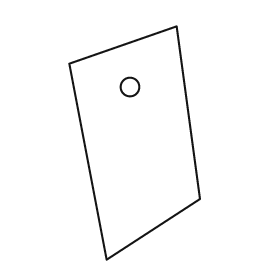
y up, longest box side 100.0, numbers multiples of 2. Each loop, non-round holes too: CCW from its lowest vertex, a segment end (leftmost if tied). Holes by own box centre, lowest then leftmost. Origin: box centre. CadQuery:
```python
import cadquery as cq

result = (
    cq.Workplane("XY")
    .moveTo(-12.0, -50.0)
    .lineTo(28.0, -24.0)
    .lineTo(18.0, 50.0)
    .lineTo(-28.0, 34.0)
    .close()
    .moveTo(-2.0, 24.0)
    .circle(4.0)
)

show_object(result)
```